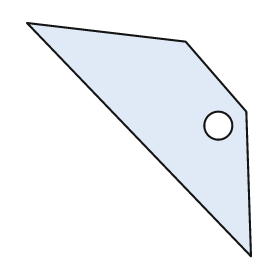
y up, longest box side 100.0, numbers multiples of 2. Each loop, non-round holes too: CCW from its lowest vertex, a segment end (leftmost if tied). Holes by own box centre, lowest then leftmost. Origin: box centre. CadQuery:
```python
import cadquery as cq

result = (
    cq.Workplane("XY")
    .moveTo(48.0, -50.0)
    .lineTo(46.0, 12.0)
    .lineTo(20.0, 42.0)
    .lineTo(-48.0, 50.0)
    .close()
    .moveTo(34.0, 6.0)
    .circle(6.0)
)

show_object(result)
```